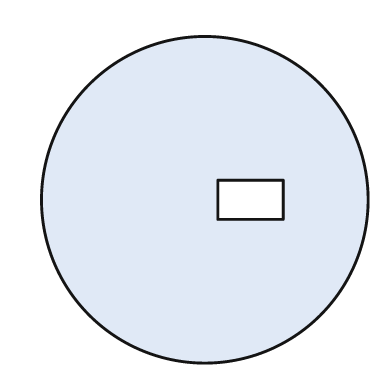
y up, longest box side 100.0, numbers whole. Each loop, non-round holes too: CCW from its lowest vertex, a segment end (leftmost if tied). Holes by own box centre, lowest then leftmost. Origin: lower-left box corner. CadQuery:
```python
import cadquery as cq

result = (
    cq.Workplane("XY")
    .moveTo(50.0, 50.0)
    .circle(50.0)
    .moveTo(54.0, 44.0)
    .lineTo(74.0, 44.0)
    .lineTo(74.0, 56.0)
    .lineTo(54.0, 56.0)
    .close()
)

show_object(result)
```